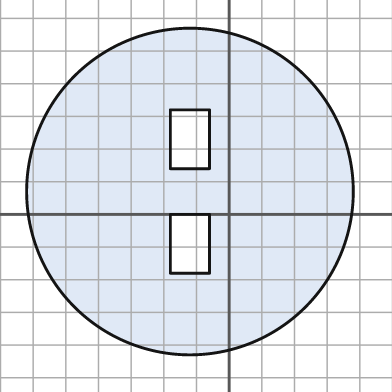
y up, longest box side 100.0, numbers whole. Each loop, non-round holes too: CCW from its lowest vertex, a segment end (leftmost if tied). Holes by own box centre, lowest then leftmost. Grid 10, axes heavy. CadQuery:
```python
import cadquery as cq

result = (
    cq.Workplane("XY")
    .moveTo(-12.0, 7.0)
    .circle(50.0)
    .moveTo(-18.0, -18.0)
    .lineTo(-6.0, -18.0)
    .lineTo(-6.0, 0.0)
    .lineTo(-18.0, 0.0)
    .close()
    .moveTo(-18.0, 14.0)
    .lineTo(-6.0, 14.0)
    .lineTo(-6.0, 32.0)
    .lineTo(-18.0, 32.0)
    .close()
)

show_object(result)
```